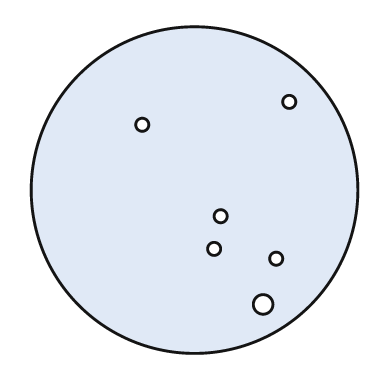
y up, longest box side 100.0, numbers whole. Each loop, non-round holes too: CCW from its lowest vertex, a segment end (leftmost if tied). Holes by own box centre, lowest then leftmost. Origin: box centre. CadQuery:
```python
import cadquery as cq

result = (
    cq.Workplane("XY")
    .moveTo(0.0, 0.0)
    .circle(50.0)
    .moveTo(21.0, -35.0)
    .circle(3.0)
    .moveTo(25.0, -21.0)
    .circle(2.0)
    .moveTo(6.0, -18.0)
    .circle(2.0)
    .moveTo(8.0, -8.0)
    .circle(2.0)
    .moveTo(-16.0, 20.0)
    .circle(2.0)
    .moveTo(29.0, 27.0)
    .circle(2.0)
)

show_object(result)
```